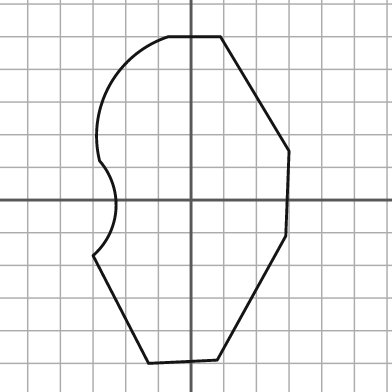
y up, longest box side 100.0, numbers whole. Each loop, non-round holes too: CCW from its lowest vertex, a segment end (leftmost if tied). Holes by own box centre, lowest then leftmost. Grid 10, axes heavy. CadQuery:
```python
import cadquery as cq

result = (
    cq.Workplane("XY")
    .moveTo(-13.0, -50.0)
    .lineTo(8.0, -49.0)
    .lineTo(29.0, -11.0)
    .lineTo(30.0, 15.0)
    .lineTo(9.0, 50.0)
    .lineTo(-7.0, 50.0)
    .threePointArc((-25.0, 35.0), (-28.0, 12.0))
    .threePointArc((-23.0, -3.0), (-30.0, -17.0))
    .close()
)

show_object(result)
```